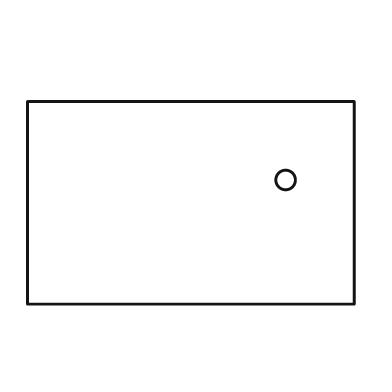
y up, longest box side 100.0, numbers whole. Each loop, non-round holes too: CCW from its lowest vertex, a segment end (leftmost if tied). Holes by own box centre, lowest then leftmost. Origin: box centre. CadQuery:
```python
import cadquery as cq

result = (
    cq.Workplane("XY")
    .moveTo(-50.0, -31.0)
    .lineTo(50.0, -31.0)
    .lineTo(50.0, 31.0)
    .lineTo(-50.0, 31.0)
    .close()
    .moveTo(29.0, 7.0)
    .circle(3.0)
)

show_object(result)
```